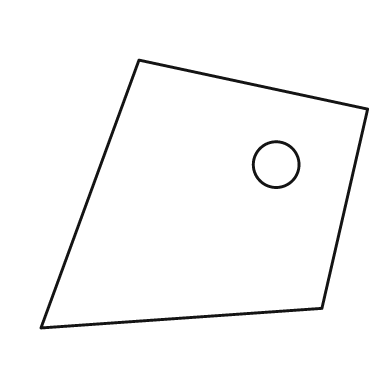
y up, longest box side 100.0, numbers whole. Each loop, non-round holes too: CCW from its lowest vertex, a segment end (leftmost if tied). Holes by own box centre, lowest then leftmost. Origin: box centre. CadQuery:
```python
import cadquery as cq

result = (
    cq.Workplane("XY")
    .moveTo(-50.0, -41.0)
    .lineTo(36.0, -35.0)
    .lineTo(50.0, 26.0)
    .lineTo(-20.0, 41.0)
    .close()
    .moveTo(22.0, 9.0)
    .circle(7.0)
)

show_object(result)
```